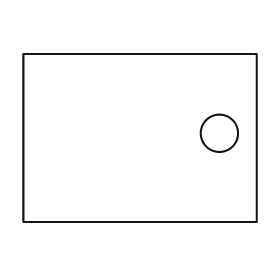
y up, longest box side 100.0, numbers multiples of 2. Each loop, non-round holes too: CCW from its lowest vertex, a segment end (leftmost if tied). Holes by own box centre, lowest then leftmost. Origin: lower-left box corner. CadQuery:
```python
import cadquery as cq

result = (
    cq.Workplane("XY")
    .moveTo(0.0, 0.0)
    .lineTo(100.0, 0.0)
    .lineTo(100.0, 72.0)
    .lineTo(0.0, 72.0)
    .close()
    .moveTo(84.0, 38.0)
    .circle(8.0)
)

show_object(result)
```